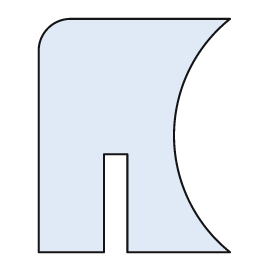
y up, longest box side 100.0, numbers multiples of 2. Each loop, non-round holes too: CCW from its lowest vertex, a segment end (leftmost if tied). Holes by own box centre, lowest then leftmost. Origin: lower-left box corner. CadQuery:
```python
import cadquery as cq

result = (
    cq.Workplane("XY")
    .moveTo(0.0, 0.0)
    .lineTo(28.0, 0.0)
    .lineTo(28.0, 42.0)
    .lineTo(38.0, 42.0)
    .lineTo(38.0, 0.0)
    .lineTo(82.0, 0.0)
    .threePointArc((58.0, 50.0), (82.0, 100.0))
    .lineTo(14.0, 100.0)
    .threePointArc((4.0, 96.0), (0.0, 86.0))
    .close()
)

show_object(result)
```